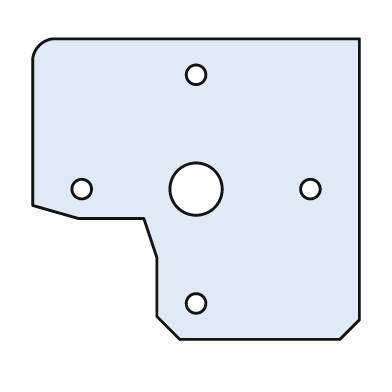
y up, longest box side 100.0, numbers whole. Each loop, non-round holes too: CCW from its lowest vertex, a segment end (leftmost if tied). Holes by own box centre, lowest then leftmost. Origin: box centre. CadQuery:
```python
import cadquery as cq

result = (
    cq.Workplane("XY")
    .moveTo(-5.0, -46.0)
    .lineTo(44.0, -46.0)
    .lineTo(50.0, -40.0)
    .lineTo(50.0, 46.0)
    .lineTo(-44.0, 46.0)
    .threePointArc((-48.0, 44.0), (-50.0, 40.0))
    .lineTo(-50.0, -5.0)
    .lineTo(-36.0, -9.0)
    .lineTo(-16.0, -9.0)
    .lineTo(-12.0, -21.0)
    .lineTo(-12.0, -39.0)
    .close()
    .moveTo(0.0, -35.0)
    .circle(3.0)
    .moveTo(-35.0, 0.0)
    .circle(3.0)
    .moveTo(0.0, 0.0)
    .circle(8.0)
    .moveTo(35.0, 0.0)
    .circle(3.0)
    .moveTo(0.0, 35.0)
    .circle(3.0)
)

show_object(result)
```